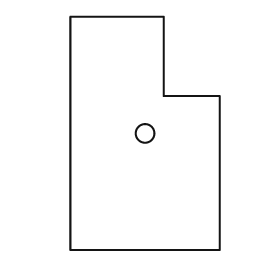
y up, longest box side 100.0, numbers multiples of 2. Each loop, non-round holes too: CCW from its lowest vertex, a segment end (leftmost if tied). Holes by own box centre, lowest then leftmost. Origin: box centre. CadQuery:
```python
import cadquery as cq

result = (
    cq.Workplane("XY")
    .moveTo(-32.0, -50.0)
    .lineTo(32.0, -50.0)
    .lineTo(32.0, 16.0)
    .lineTo(8.0, 16.0)
    .lineTo(8.0, 50.0)
    .lineTo(-32.0, 50.0)
    .close()
    .moveTo(0.0, 0.0)
    .circle(4.0)
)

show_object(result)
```